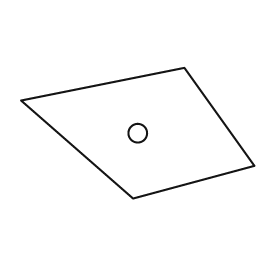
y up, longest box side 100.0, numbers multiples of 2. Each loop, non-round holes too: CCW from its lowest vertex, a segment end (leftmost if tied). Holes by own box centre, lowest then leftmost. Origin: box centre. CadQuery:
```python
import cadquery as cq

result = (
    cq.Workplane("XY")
    .moveTo(-2.0, -28.0)
    .lineTo(50.0, -14.0)
    .lineTo(20.0, 28.0)
    .lineTo(-50.0, 14.0)
    .close()
    .moveTo(0.0, 0.0)
    .circle(4.0)
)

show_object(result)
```